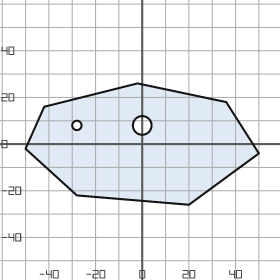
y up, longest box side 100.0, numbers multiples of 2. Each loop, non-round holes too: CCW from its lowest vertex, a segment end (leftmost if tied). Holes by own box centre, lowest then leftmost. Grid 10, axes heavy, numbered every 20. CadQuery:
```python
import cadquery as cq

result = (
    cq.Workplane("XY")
    .moveTo(20.0, -26.0)
    .lineTo(50.0, -4.0)
    .lineTo(36.0, 18.0)
    .lineTo(-2.0, 26.0)
    .lineTo(-42.0, 16.0)
    .lineTo(-50.0, -2.0)
    .lineTo(-28.0, -22.0)
    .close()
    .moveTo(-28.0, 8.0)
    .circle(2.0)
    .moveTo(0.0, 8.0)
    .circle(4.0)
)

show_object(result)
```